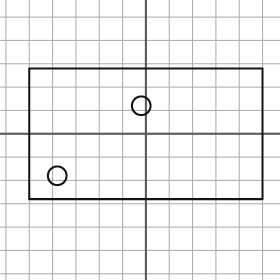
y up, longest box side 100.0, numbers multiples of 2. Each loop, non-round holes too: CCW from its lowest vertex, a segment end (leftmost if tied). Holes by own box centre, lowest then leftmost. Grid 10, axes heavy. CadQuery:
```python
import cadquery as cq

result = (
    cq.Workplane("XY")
    .moveTo(-50.0, -28.0)
    .lineTo(50.0, -28.0)
    .lineTo(50.0, 28.0)
    .lineTo(-50.0, 28.0)
    .close()
    .moveTo(-38.0, -18.0)
    .circle(4.0)
    .moveTo(-2.0, 12.0)
    .circle(4.0)
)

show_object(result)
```